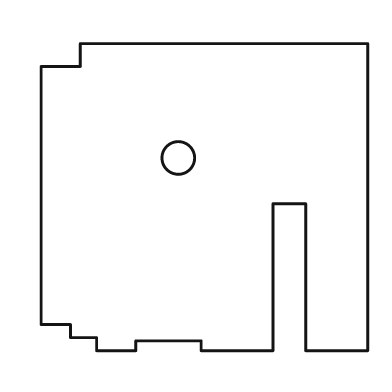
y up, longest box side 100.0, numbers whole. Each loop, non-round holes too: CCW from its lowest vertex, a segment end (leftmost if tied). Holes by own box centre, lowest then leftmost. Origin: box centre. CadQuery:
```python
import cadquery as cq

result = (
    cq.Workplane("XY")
    .moveTo(-33.0, -47.0)
    .lineTo(-21.0, -47.0)
    .lineTo(-21.0, -44.0)
    .lineTo(-1.0, -44.0)
    .lineTo(-1.0, -47.0)
    .lineTo(21.0, -47.0)
    .lineTo(21.0, -2.0)
    .lineTo(31.0, -2.0)
    .lineTo(31.0, -47.0)
    .lineTo(50.0, -47.0)
    .lineTo(50.0, 47.0)
    .lineTo(-38.0, 47.0)
    .lineTo(-38.0, 40.0)
    .lineTo(-50.0, 40.0)
    .lineTo(-50.0, -39.0)
    .lineTo(-41.0, -39.0)
    .lineTo(-41.0, -43.0)
    .lineTo(-33.0, -43.0)
    .close()
    .moveTo(-8.0, 12.0)
    .circle(5.0)
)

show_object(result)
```